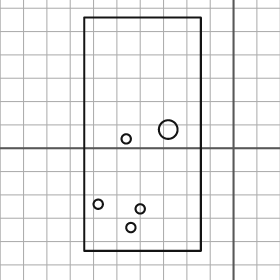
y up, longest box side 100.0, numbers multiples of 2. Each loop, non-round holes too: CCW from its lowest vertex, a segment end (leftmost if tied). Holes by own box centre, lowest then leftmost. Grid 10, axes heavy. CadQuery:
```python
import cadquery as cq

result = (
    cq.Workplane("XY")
    .moveTo(-64.0, -44.0)
    .lineTo(-14.0, -44.0)
    .lineTo(-14.0, 56.0)
    .lineTo(-64.0, 56.0)
    .close()
    .moveTo(-44.0, -34.0)
    .circle(2.0)
    .moveTo(-40.0, -26.0)
    .circle(2.0)
    .moveTo(-58.0, -24.0)
    .circle(2.0)
    .moveTo(-46.0, 4.0)
    .circle(2.0)
    .moveTo(-28.0, 8.0)
    .circle(4.0)
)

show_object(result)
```